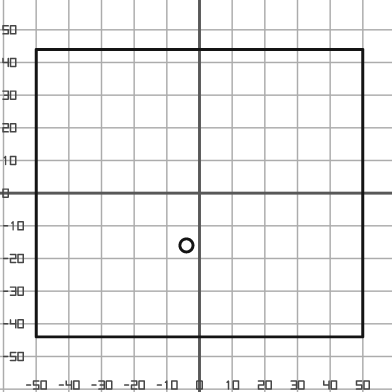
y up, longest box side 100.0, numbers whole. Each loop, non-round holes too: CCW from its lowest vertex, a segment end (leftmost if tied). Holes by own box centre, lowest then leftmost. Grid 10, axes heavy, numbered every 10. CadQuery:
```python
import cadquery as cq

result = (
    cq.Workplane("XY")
    .moveTo(-50.0, -44.0)
    .lineTo(50.0, -44.0)
    .lineTo(50.0, 44.0)
    .lineTo(-50.0, 44.0)
    .close()
    .moveTo(-4.0, -16.0)
    .circle(2.0)
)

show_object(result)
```